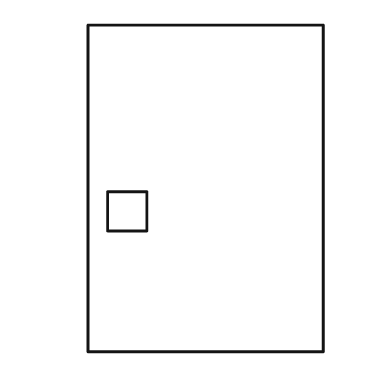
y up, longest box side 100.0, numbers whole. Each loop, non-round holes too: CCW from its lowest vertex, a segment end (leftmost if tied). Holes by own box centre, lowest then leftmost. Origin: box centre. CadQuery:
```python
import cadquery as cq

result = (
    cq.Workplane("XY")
    .moveTo(-36.0, -50.0)
    .lineTo(36.0, -50.0)
    .lineTo(36.0, 50.0)
    .lineTo(-36.0, 50.0)
    .close()
    .moveTo(-30.0, -13.0)
    .lineTo(-18.0, -13.0)
    .lineTo(-18.0, -1.0)
    .lineTo(-30.0, -1.0)
    .close()
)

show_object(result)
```